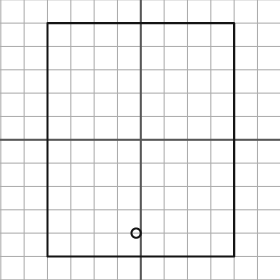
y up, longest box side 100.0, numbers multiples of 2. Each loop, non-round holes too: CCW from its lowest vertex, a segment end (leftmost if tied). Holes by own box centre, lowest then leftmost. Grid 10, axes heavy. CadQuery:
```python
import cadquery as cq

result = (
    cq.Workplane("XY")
    .moveTo(-40.0, -50.0)
    .lineTo(40.0, -50.0)
    .lineTo(40.0, 50.0)
    .lineTo(-40.0, 50.0)
    .close()
    .moveTo(-2.0, -40.0)
    .circle(2.0)
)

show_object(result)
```